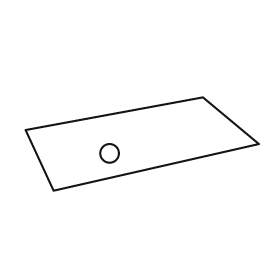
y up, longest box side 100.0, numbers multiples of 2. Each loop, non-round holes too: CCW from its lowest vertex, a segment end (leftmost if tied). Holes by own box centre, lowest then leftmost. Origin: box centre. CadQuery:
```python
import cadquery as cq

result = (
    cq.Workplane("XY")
    .moveTo(-38.0, -20.0)
    .lineTo(50.0, 0.0)
    .lineTo(26.0, 20.0)
    .lineTo(-50.0, 6.0)
    .close()
    .moveTo(-14.0, -4.0)
    .circle(4.0)
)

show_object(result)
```